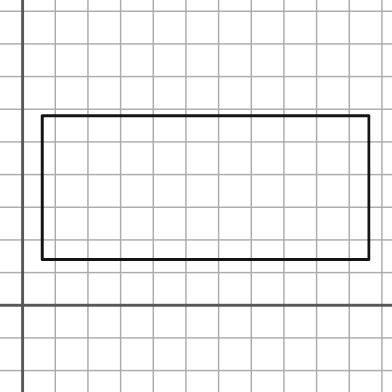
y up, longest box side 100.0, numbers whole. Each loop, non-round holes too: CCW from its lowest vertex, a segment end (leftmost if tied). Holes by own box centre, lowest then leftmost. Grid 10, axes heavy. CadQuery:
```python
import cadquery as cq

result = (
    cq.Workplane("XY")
    .moveTo(6.0, 14.0)
    .lineTo(106.0, 14.0)
    .lineTo(106.0, 58.0)
    .lineTo(6.0, 58.0)
    .close()
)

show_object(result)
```